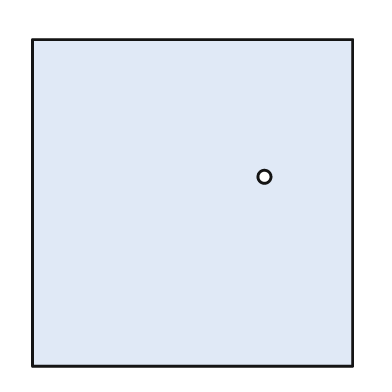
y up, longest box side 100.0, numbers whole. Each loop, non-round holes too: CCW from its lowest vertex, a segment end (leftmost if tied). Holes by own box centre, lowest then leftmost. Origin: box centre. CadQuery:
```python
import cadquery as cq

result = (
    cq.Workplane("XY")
    .moveTo(-49.0, -50.0)
    .lineTo(49.0, -50.0)
    .lineTo(49.0, 50.0)
    .lineTo(-49.0, 50.0)
    .close()
    .moveTo(22.0, 8.0)
    .circle(2.0)
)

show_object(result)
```